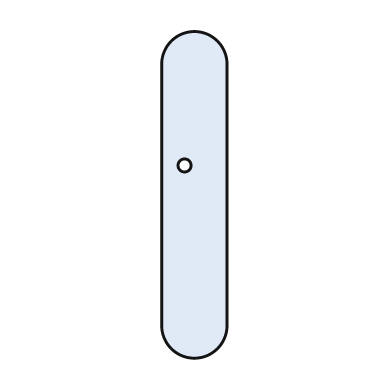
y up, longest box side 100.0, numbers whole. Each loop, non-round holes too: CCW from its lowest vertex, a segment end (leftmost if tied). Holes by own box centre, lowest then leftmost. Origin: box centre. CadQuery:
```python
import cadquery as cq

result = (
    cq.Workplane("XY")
    .moveTo(-10.0, -40.0)
    .threePointArc((0.0, -50.0), (10.0, -40.0))
    .lineTo(10.0, 40.0)
    .threePointArc((0.0, 50.0), (-10.0, 40.0))
    .close()
    .moveTo(-3.0, 9.0)
    .circle(2.0)
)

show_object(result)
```